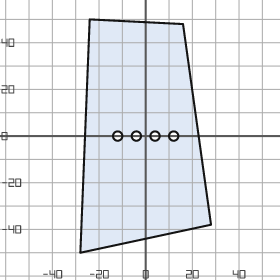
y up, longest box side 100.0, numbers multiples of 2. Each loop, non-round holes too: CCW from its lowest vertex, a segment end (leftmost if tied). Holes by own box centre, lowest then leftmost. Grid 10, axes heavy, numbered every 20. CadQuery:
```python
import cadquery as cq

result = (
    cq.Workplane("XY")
    .moveTo(-28.0, -50.0)
    .lineTo(28.0, -38.0)
    .lineTo(16.0, 48.0)
    .lineTo(-24.0, 50.0)
    .close()
    .moveTo(-12.0, 0.0)
    .circle(2.0)
    .moveTo(-4.0, 0.0)
    .circle(2.0)
    .moveTo(4.0, 0.0)
    .circle(2.0)
    .moveTo(12.0, 0.0)
    .circle(2.0)
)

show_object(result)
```